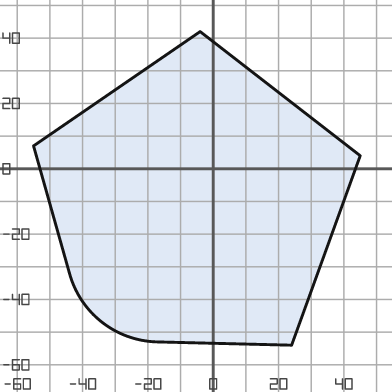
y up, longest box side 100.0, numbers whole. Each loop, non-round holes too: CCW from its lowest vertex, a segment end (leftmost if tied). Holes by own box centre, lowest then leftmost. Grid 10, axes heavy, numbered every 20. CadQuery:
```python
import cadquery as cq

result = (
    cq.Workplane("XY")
    .moveTo(24.0, -54.0)
    .lineTo(45.0, 4.0)
    .lineTo(-4.0, 42.0)
    .lineTo(-55.0, 7.0)
    .lineTo(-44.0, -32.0)
    .threePointArc((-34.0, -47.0), (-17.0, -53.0))
    .close()
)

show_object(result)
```